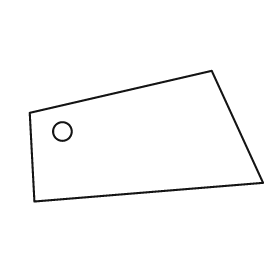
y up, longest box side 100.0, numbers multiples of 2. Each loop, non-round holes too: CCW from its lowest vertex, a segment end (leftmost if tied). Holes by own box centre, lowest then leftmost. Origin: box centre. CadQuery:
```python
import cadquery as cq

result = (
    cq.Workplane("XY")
    .moveTo(-48.0, -28.0)
    .lineTo(50.0, -20.0)
    .lineTo(28.0, 28.0)
    .lineTo(-50.0, 10.0)
    .close()
    .moveTo(-36.0, 2.0)
    .circle(4.0)
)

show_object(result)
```